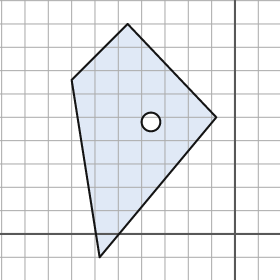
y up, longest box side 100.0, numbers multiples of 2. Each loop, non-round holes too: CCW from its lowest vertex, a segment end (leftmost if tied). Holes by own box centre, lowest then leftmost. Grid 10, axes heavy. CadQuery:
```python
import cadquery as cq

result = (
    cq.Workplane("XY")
    .moveTo(-58.0, -10.0)
    .lineTo(-8.0, 50.0)
    .lineTo(-46.0, 90.0)
    .lineTo(-70.0, 66.0)
    .close()
    .moveTo(-36.0, 48.0)
    .circle(4.0)
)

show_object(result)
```